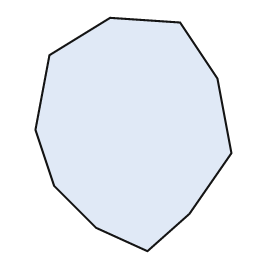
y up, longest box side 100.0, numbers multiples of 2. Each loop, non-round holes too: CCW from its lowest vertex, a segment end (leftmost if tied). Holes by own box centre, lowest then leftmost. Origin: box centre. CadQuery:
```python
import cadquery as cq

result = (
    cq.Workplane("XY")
    .moveTo(6.0, -50.0)
    .lineTo(24.0, -34.0)
    .lineTo(42.0, -8.0)
    .lineTo(36.0, 24.0)
    .lineTo(20.0, 48.0)
    .lineTo(-10.0, 50.0)
    .lineTo(-36.0, 34.0)
    .lineTo(-42.0, 2.0)
    .lineTo(-34.0, -22.0)
    .lineTo(-16.0, -40.0)
    .close()
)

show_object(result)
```